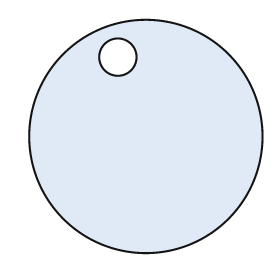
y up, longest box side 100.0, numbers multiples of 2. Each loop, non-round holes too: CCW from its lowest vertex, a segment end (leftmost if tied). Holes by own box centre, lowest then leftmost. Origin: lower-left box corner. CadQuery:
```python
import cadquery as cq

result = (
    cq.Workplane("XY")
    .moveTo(50.0, 50.0)
    .circle(50.0)
    .moveTo(38.0, 84.0)
    .circle(8.0)
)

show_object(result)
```